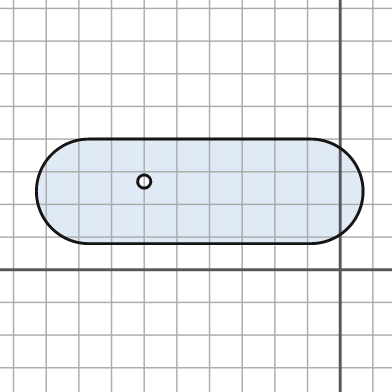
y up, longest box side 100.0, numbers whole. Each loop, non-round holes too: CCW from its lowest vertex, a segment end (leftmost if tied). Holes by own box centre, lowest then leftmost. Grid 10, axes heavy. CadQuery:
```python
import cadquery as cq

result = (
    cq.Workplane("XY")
    .moveTo(-77.0, 8.0)
    .lineTo(-9.0, 8.0)
    .threePointArc((7.0, 24.0), (-9.0, 40.0))
    .lineTo(-77.0, 40.0)
    .threePointArc((-93.0, 24.0), (-77.0, 8.0))
    .close()
    .moveTo(-60.0, 27.0)
    .circle(2.0)
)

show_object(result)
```